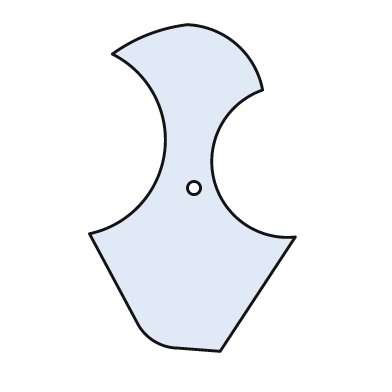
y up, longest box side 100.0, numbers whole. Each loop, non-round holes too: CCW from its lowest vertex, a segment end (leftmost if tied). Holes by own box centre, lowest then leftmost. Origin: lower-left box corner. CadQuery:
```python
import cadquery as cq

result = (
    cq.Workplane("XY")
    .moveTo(40.0, 0.0)
    .lineTo(63.0, 35.0)
    .threePointArc((38.0, 53.0), (53.0, 80.0))
    .threePointArc((45.0, 94.0), (30.0, 100.0))
    .threePointArc((18.0, 97.0), (7.0, 91.0))
    .threePointArc((23.0, 61.0), (0.0, 36.0))
    .lineTo(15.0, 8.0)
    .threePointArc((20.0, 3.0), (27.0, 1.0))
    .close()
    .moveTo(32.0, 50.0)
    .circle(2.0)
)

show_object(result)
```